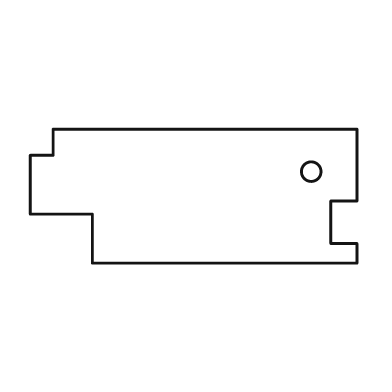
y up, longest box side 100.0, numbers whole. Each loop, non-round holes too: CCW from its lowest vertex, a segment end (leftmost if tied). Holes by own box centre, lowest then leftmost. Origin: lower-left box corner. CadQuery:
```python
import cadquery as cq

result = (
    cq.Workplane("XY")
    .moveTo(19.0, 0.0)
    .lineTo(100.0, 0.0)
    .lineTo(100.0, 6.0)
    .lineTo(92.0, 6.0)
    .lineTo(92.0, 19.0)
    .lineTo(100.0, 19.0)
    .lineTo(100.0, 41.0)
    .lineTo(7.0, 41.0)
    .lineTo(7.0, 33.0)
    .lineTo(0.0, 33.0)
    .lineTo(0.0, 15.0)
    .lineTo(19.0, 15.0)
    .close()
    .moveTo(86.0, 28.0)
    .circle(3.0)
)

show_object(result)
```